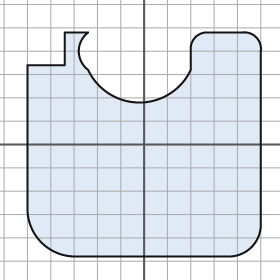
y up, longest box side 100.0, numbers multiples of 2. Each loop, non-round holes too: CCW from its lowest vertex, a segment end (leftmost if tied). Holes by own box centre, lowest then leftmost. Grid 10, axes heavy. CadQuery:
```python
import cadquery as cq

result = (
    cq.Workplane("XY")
    .moveTo(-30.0, -48.0)
    .lineTo(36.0, -48.0)
    .threePointArc((46.0, -44.0), (50.0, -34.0))
    .lineTo(50.0, 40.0)
    .threePointArc((48.0, 46.0), (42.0, 48.0))
    .lineTo(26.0, 48.0)
    .threePointArc((22.0, 46.0), (20.0, 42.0))
    .lineTo(20.0, 32.0)
    .threePointArc((-2.0, 18.0), (-24.0, 32.0))
    .threePointArc((-28.0, 40.0), (-24.0, 48.0))
    .lineTo(-34.0, 48.0)
    .lineTo(-34.0, 34.0)
    .lineTo(-50.0, 34.0)
    .lineTo(-50.0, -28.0)
    .threePointArc((-44.0, -42.0), (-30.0, -48.0))
    .close()
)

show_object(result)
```